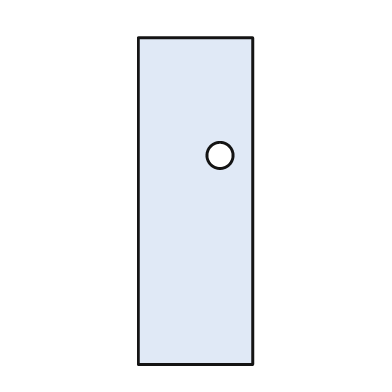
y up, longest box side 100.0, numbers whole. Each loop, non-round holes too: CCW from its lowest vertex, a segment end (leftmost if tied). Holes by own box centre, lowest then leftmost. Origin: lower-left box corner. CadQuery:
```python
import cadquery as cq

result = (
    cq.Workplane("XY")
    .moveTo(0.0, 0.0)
    .lineTo(35.0, 0.0)
    .lineTo(35.0, 100.0)
    .lineTo(0.0, 100.0)
    .close()
    .moveTo(25.0, 64.0)
    .circle(4.0)
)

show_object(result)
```